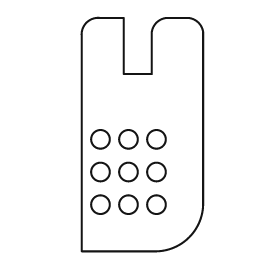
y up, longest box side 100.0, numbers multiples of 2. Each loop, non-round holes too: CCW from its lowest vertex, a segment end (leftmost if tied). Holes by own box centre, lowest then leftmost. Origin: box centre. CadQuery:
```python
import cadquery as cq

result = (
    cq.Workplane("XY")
    .moveTo(-26.0, -50.0)
    .lineTo(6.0, -50.0)
    .threePointArc((20.0, -44.0), (26.0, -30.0))
    .lineTo(26.0, 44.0)
    .threePointArc((24.0, 48.0), (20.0, 50.0))
    .lineTo(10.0, 50.0)
    .threePointArc((6.0, 48.0), (4.0, 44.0))
    .lineTo(4.0, 26.0)
    .lineTo(-8.0, 26.0)
    .lineTo(-8.0, 50.0)
    .lineTo(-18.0, 50.0)
    .threePointArc((-24.0, 48.0), (-26.0, 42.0))
    .close()
    .moveTo(-18.0, -30.0)
    .circle(4.0)
    .moveTo(-6.0, -30.0)
    .circle(4.0)
    .moveTo(6.0, -30.0)
    .circle(4.0)
    .moveTo(-18.0, -16.0)
    .circle(4.0)
    .moveTo(-6.0, -16.0)
    .circle(4.0)
    .moveTo(6.0, -16.0)
    .circle(4.0)
    .moveTo(-18.0, -2.0)
    .circle(4.0)
    .moveTo(-6.0, -2.0)
    .circle(4.0)
    .moveTo(6.0, -2.0)
    .circle(4.0)
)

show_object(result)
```